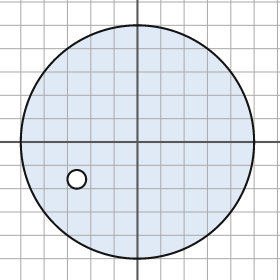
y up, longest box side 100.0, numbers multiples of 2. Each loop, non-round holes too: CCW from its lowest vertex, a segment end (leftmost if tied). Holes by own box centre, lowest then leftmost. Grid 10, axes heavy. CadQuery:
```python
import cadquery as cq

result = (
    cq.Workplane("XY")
    .moveTo(0.0, 0.0)
    .circle(50.0)
    .moveTo(-26.0, -16.0)
    .circle(4.0)
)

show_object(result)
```